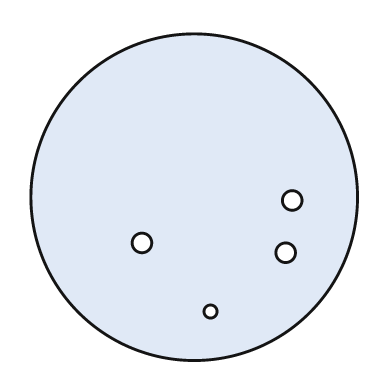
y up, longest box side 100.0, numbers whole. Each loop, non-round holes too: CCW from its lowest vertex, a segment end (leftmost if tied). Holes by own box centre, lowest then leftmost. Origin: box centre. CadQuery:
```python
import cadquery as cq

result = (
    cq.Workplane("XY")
    .moveTo(0.0, 0.0)
    .circle(50.0)
    .moveTo(5.0, -35.0)
    .circle(2.0)
    .moveTo(28.0, -17.0)
    .circle(3.0)
    .moveTo(-16.0, -14.0)
    .circle(3.0)
    .moveTo(30.0, -1.0)
    .circle(3.0)
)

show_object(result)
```